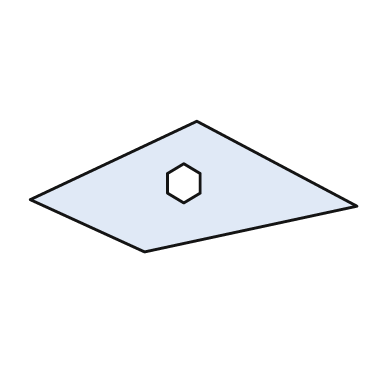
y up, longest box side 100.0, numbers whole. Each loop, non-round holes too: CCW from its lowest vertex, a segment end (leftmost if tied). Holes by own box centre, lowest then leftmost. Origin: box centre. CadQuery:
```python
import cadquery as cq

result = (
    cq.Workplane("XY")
    .moveTo(-15.0, -20.0)
    .lineTo(50.0, -6.0)
    .lineTo(1.0, 20.0)
    .lineTo(-50.0, -4.0)
    .close()
    .moveTo(-3.0, -5.0)
    .lineTo(2.0, -2.0)
    .lineTo(2.0, 4.0)
    .lineTo(-3.0, 7.0)
    .lineTo(-8.0, 4.0)
    .lineTo(-8.0, -2.0)
    .close()
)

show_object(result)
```